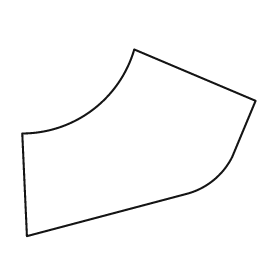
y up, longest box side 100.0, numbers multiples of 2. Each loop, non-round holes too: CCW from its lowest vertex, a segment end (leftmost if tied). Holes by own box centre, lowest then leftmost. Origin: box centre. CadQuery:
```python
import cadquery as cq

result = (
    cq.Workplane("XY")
    .moveTo(-48.0, -40.0)
    .lineTo(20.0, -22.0)
    .threePointArc((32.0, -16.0), (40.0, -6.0))
    .lineTo(50.0, 18.0)
    .lineTo(-2.0, 40.0)
    .threePointArc((-20.0, 14.0), (-50.0, 4.0))
    .close()
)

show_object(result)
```